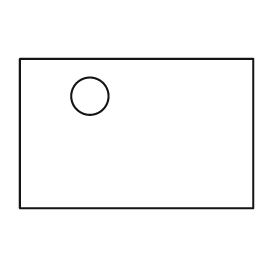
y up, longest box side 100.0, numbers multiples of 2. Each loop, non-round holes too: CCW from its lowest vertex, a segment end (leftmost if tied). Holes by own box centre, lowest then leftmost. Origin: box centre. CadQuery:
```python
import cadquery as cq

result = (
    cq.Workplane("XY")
    .moveTo(-50.0, -32.0)
    .lineTo(50.0, -32.0)
    .lineTo(50.0, 32.0)
    .lineTo(-50.0, 32.0)
    .close()
    .moveTo(-20.0, 16.0)
    .circle(8.0)
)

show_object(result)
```